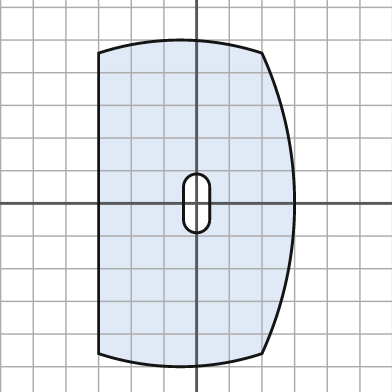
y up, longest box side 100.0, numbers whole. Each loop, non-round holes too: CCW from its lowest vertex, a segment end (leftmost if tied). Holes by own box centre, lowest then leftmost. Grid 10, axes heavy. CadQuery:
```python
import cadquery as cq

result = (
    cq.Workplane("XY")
    .moveTo(-30.0, -46.0)
    .threePointArc((-5.0, -50.0), (20.0, -46.0))
    .threePointArc((30.0, 0.0), (20.0, 46.0))
    .threePointArc((-5.0, 50.0), (-30.0, 46.0))
    .close()
    .moveTo(-4.0, -5.0)
    .threePointArc((0.0, -9.0), (4.0, -5.0))
    .lineTo(4.0, 5.0)
    .threePointArc((0.0, 9.0), (-4.0, 5.0))
    .close()
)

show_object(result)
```